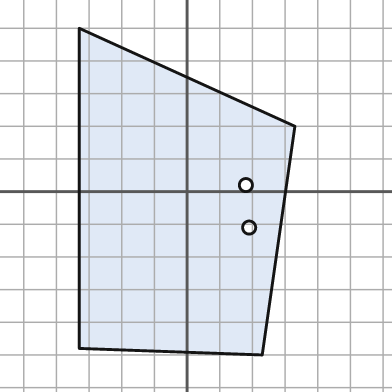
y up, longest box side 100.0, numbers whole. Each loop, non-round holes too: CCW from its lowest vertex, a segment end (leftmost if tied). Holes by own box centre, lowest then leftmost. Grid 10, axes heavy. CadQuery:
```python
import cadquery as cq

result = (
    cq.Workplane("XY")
    .moveTo(23.0, -50.0)
    .lineTo(33.0, 20.0)
    .lineTo(-33.0, 50.0)
    .lineTo(-33.0, -48.0)
    .close()
    .moveTo(19.0, -11.0)
    .circle(2.0)
    .moveTo(18.0, 2.0)
    .circle(2.0)
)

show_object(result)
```